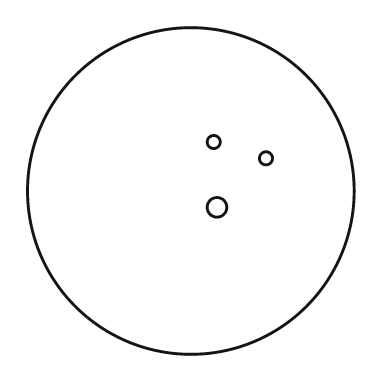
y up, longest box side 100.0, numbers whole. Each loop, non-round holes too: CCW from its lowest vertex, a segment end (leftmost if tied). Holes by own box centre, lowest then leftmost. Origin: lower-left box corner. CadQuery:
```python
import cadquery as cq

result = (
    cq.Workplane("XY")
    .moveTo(50.0, 50.0)
    .circle(50.0)
    .moveTo(58.0, 45.0)
    .circle(3.0)
    .moveTo(73.0, 60.0)
    .circle(2.0)
    .moveTo(57.0, 65.0)
    .circle(2.0)
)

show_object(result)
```